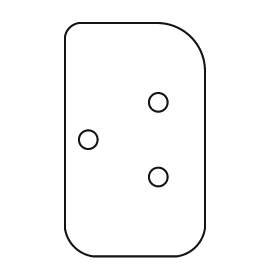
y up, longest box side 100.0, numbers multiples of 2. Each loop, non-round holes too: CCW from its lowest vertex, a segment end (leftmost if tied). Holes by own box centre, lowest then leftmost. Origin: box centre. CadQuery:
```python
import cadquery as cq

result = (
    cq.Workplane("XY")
    .moveTo(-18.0, -50.0)
    .lineTo(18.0, -50.0)
    .threePointArc((26.0, -46.0), (30.0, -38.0))
    .lineTo(30.0, 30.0)
    .threePointArc((24.0, 44.0), (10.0, 50.0))
    .lineTo(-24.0, 50.0)
    .threePointArc((-28.0, 48.0), (-30.0, 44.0))
    .lineTo(-30.0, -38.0)
    .threePointArc((-26.0, -46.0), (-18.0, -50.0))
    .close()
    .moveTo(10.0, -16.0)
    .circle(4.0)
    .moveTo(-20.0, 0.0)
    .circle(4.0)
    .moveTo(10.0, 16.0)
    .circle(4.0)
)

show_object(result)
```